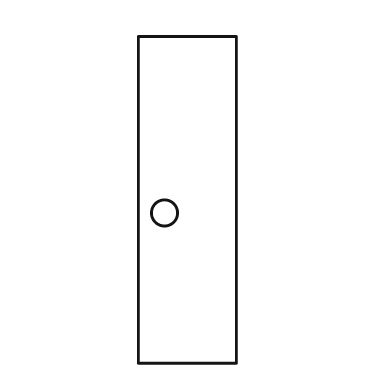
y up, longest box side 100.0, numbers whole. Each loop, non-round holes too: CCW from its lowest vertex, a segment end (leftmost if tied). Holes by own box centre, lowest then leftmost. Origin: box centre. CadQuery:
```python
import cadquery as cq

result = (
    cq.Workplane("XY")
    .moveTo(-15.0, -50.0)
    .lineTo(15.0, -50.0)
    .lineTo(15.0, 50.0)
    .lineTo(-15.0, 50.0)
    .close()
    .moveTo(-7.0, -4.0)
    .circle(4.0)
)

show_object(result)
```